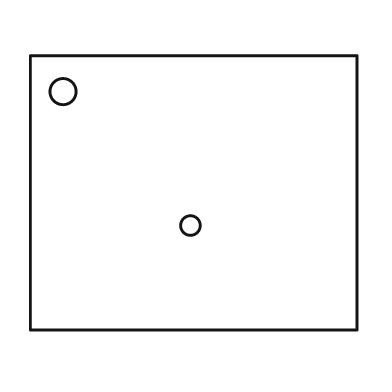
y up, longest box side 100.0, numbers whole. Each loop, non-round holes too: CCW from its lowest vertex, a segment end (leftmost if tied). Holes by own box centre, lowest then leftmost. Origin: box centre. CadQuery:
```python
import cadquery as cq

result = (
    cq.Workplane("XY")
    .moveTo(-50.0, -42.0)
    .lineTo(50.0, -42.0)
    .lineTo(50.0, 42.0)
    .lineTo(-50.0, 42.0)
    .close()
    .moveTo(-1.0, -10.0)
    .circle(3.0)
    .moveTo(-40.0, 31.0)
    .circle(4.0)
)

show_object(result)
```